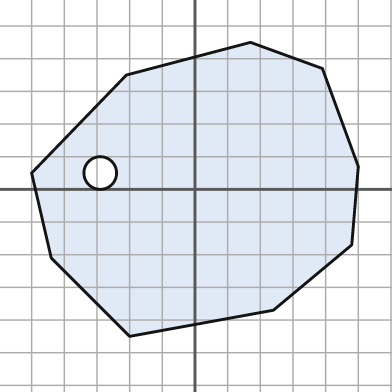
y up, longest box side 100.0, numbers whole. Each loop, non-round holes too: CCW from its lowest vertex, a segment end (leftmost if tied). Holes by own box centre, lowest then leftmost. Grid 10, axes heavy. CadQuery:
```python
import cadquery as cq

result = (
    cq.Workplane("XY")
    .moveTo(-20.0, -45.0)
    .lineTo(24.0, -37.0)
    .lineTo(48.0, -17.0)
    .lineTo(50.0, 7.0)
    .lineTo(39.0, 37.0)
    .lineTo(17.0, 45.0)
    .lineTo(-21.0, 35.0)
    .lineTo(-50.0, 5.0)
    .lineTo(-44.0, -21.0)
    .close()
    .moveTo(-29.0, 5.0)
    .circle(5.0)
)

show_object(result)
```